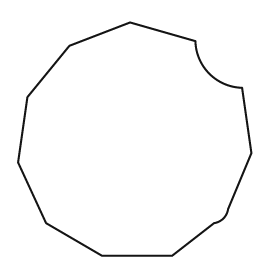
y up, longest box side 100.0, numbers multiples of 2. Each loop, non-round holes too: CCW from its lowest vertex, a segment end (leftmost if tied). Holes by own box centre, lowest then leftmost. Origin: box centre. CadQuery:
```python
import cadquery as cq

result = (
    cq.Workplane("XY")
    .moveTo(-14.0, -50.0)
    .lineTo(16.0, -50.0)
    .lineTo(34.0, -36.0)
    .threePointArc((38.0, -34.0), (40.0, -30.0))
    .lineTo(50.0, -6.0)
    .lineTo(46.0, 22.0)
    .threePointArc((32.0, 28.0), (26.0, 42.0))
    .lineTo(-2.0, 50.0)
    .lineTo(-28.0, 40.0)
    .lineTo(-46.0, 18.0)
    .lineTo(-50.0, -10.0)
    .lineTo(-38.0, -36.0)
    .close()
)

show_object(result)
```